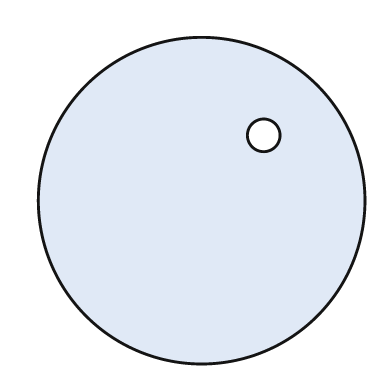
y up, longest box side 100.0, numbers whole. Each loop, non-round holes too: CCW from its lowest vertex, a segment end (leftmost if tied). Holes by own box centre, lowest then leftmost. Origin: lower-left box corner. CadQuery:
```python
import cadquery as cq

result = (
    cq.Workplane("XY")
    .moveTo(50.0, 50.0)
    .circle(50.0)
    .moveTo(69.0, 70.0)
    .circle(5.0)
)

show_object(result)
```